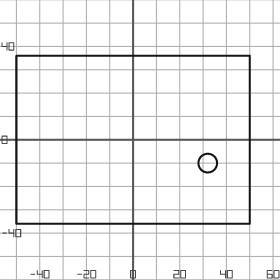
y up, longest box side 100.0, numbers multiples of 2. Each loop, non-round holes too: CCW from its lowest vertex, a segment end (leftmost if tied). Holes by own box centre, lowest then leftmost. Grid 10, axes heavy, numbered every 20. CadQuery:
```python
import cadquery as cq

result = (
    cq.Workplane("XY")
    .moveTo(-50.0, -36.0)
    .lineTo(50.0, -36.0)
    .lineTo(50.0, 36.0)
    .lineTo(-50.0, 36.0)
    .close()
    .moveTo(32.0, -10.0)
    .circle(4.0)
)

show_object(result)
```